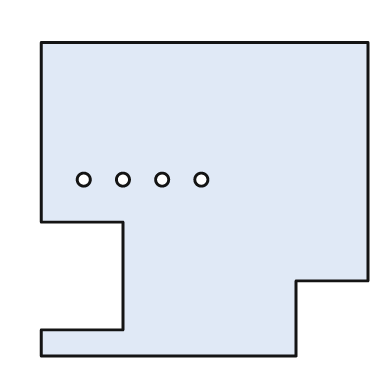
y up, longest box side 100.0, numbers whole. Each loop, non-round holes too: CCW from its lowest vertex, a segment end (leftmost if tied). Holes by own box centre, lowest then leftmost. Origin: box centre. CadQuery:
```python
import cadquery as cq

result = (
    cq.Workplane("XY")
    .moveTo(-50.0, -48.0)
    .lineTo(28.0, -48.0)
    .lineTo(28.0, -25.0)
    .lineTo(50.0, -25.0)
    .lineTo(50.0, 48.0)
    .lineTo(-50.0, 48.0)
    .lineTo(-50.0, -7.0)
    .lineTo(-25.0, -7.0)
    .lineTo(-25.0, -40.0)
    .lineTo(-50.0, -40.0)
    .close()
    .moveTo(-37.0, 6.0)
    .circle(2.0)
    .moveTo(-25.0, 6.0)
    .circle(2.0)
    .moveTo(-13.0, 6.0)
    .circle(2.0)
    .moveTo(-1.0, 6.0)
    .circle(2.0)
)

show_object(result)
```